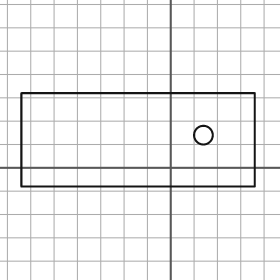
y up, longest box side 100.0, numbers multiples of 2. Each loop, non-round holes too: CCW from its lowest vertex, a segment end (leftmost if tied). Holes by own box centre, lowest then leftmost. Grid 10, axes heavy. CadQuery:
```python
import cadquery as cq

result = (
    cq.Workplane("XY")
    .moveTo(-64.0, -8.0)
    .lineTo(36.0, -8.0)
    .lineTo(36.0, 32.0)
    .lineTo(-64.0, 32.0)
    .close()
    .moveTo(14.0, 14.0)
    .circle(4.0)
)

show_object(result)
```